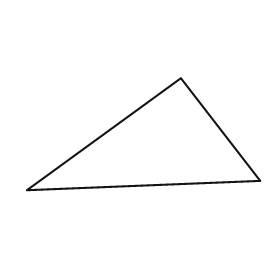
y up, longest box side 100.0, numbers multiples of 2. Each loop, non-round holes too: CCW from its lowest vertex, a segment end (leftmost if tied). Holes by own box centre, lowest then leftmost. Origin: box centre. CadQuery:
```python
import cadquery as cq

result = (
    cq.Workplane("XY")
    .moveTo(-50.0, -24.0)
    .lineTo(50.0, -20.0)
    .lineTo(16.0, 24.0)
    .close()
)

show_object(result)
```